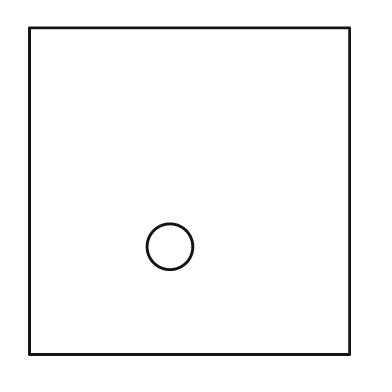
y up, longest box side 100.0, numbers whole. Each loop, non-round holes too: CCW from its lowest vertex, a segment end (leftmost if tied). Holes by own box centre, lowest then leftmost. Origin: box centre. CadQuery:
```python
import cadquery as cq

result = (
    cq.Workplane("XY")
    .moveTo(-49.0, -50.0)
    .lineTo(49.0, -50.0)
    .lineTo(49.0, 50.0)
    .lineTo(-49.0, 50.0)
    .close()
    .moveTo(-6.0, -17.0)
    .circle(7.0)
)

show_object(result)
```